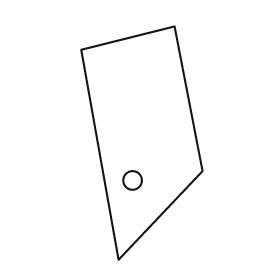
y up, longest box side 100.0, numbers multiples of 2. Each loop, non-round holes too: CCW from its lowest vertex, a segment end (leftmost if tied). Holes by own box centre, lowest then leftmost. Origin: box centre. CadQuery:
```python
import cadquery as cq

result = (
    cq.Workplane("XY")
    .moveTo(-10.0, -50.0)
    .lineTo(26.0, -12.0)
    .lineTo(14.0, 50.0)
    .lineTo(-26.0, 40.0)
    .close()
    .moveTo(-4.0, -16.0)
    .circle(4.0)
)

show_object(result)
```